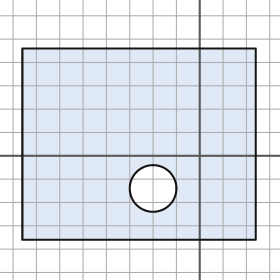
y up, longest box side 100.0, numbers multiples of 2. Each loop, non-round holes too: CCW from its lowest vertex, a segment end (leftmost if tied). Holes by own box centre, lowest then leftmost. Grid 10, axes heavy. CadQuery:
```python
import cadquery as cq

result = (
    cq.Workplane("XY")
    .moveTo(-76.0, -36.0)
    .lineTo(24.0, -36.0)
    .lineTo(24.0, 46.0)
    .lineTo(-76.0, 46.0)
    .close()
    .moveTo(-20.0, -14.0)
    .circle(10.0)
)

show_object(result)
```